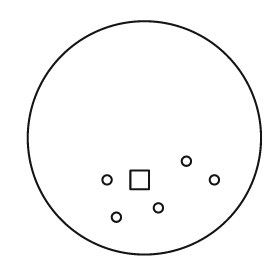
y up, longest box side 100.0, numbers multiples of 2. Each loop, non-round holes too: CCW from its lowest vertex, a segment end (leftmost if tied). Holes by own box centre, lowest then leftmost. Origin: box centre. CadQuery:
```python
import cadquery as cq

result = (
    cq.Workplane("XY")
    .moveTo(0.0, 0.0)
    .circle(50.0)
    .moveTo(-12.0, -34.0)
    .circle(2.0)
    .moveTo(6.0, -30.0)
    .circle(2.0)
    .moveTo(-16.0, -18.0)
    .circle(2.0)
    .moveTo(-6.0, -22.0)
    .lineTo(2.0, -22.0)
    .lineTo(2.0, -14.0)
    .lineTo(-6.0, -14.0)
    .close()
    .moveTo(30.0, -18.0)
    .circle(2.0)
    .moveTo(18.0, -10.0)
    .circle(2.0)
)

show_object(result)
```